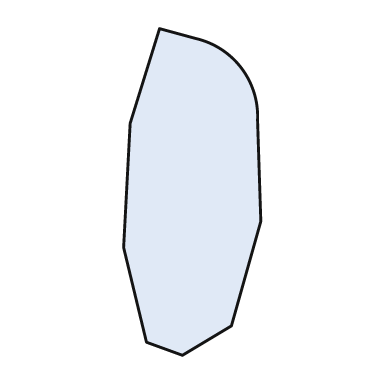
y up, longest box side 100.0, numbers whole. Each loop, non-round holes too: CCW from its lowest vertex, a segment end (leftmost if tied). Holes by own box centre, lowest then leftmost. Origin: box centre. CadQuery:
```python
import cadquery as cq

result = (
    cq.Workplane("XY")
    .moveTo(-3.0, -50.0)
    .lineTo(12.0, -41.0)
    .lineTo(21.0, -9.0)
    .lineTo(20.0, 22.0)
    .threePointArc((15.0, 38.0), (1.0, 47.0))
    .lineTo(-10.0, 50.0)
    .lineTo(-19.0, 21.0)
    .lineTo(-21.0, -17.0)
    .lineTo(-14.0, -46.0)
    .close()
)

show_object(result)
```